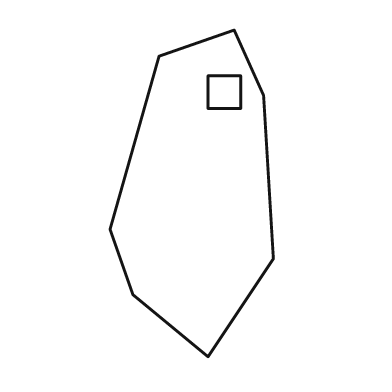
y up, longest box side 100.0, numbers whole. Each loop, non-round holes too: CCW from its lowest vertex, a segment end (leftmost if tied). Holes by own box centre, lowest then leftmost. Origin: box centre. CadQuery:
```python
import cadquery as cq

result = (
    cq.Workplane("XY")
    .moveTo(5.0, -50.0)
    .lineTo(25.0, -20.0)
    .lineTo(22.0, 30.0)
    .lineTo(13.0, 50.0)
    .lineTo(-10.0, 42.0)
    .lineTo(-25.0, -11.0)
    .lineTo(-18.0, -31.0)
    .close()
    .moveTo(5.0, 26.0)
    .lineTo(15.0, 26.0)
    .lineTo(15.0, 36.0)
    .lineTo(5.0, 36.0)
    .close()
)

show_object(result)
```